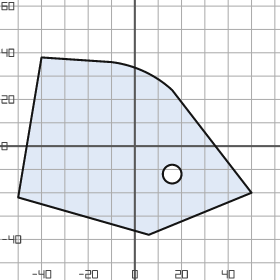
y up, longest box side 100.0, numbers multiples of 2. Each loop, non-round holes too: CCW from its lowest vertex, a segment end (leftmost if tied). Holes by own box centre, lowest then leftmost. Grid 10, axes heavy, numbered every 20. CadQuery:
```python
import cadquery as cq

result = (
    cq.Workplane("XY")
    .moveTo(6.0, -38.0)
    .lineTo(50.0, -20.0)
    .lineTo(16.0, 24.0)
    .threePointArc((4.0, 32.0), (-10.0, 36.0))
    .lineTo(-40.0, 38.0)
    .lineTo(-50.0, -22.0)
    .close()
    .moveTo(16.0, -12.0)
    .circle(4.0)
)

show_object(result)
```